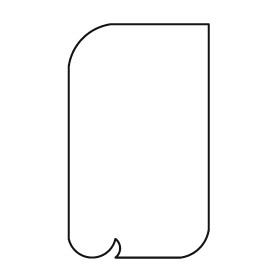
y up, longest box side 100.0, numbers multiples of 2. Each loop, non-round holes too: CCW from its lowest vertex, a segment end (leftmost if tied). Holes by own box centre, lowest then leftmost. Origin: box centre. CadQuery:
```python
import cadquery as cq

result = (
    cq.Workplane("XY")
    .moveTo(-10.0, -50.0)
    .lineTo(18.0, -50.0)
    .threePointArc((26.0, -46.0), (30.0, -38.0))
    .lineTo(30.0, 50.0)
    .lineTo(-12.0, 50.0)
    .threePointArc((-24.0, 44.0), (-30.0, 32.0))
    .lineTo(-30.0, -42.0)
    .threePointArc((-20.0, -50.0), (-10.0, -42.0))
    .threePointArc((-8.0, -46.0), (-10.0, -50.0))
    .close()
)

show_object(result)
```